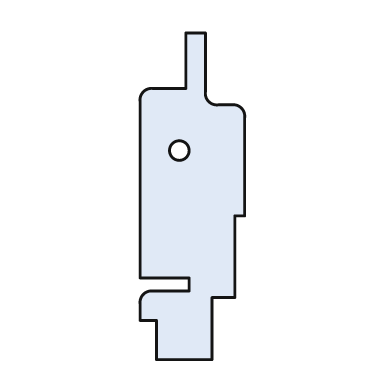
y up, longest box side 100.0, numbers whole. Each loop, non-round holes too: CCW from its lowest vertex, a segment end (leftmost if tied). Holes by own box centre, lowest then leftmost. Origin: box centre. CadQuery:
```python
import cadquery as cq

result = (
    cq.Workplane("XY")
    .moveTo(-11.0, -50.0)
    .lineTo(6.0, -50.0)
    .lineTo(6.0, -31.0)
    .lineTo(13.0, -31.0)
    .lineTo(13.0, -6.0)
    .lineTo(16.0, -6.0)
    .lineTo(16.0, 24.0)
    .threePointArc((15.0, 27.0), (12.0, 28.0))
    .lineTo(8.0, 28.0)
    .threePointArc((5.0, 29.0), (4.0, 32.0))
    .lineTo(4.0, 50.0)
    .lineTo(-2.0, 50.0)
    .lineTo(-2.0, 33.0)
    .lineTo(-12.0, 33.0)
    .threePointArc((-15.0, 32.0), (-16.0, 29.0))
    .lineTo(-16.0, -25.0)
    .lineTo(-1.0, -25.0)
    .lineTo(-1.0, -29.0)
    .lineTo(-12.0, -29.0)
    .threePointArc((-15.0, -30.0), (-16.0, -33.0))
    .lineTo(-16.0, -38.0)
    .lineTo(-11.0, -38.0)
    .close()
    .moveTo(-4.0, 14.0)
    .circle(3.0)
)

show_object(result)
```